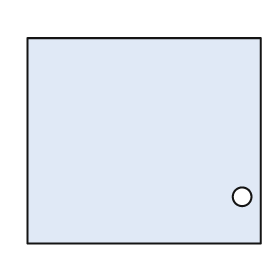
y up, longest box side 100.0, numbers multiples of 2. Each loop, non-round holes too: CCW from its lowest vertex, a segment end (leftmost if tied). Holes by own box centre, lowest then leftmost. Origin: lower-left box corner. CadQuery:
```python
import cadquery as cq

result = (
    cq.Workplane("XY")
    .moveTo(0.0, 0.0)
    .lineTo(100.0, 0.0)
    .lineTo(100.0, 88.0)
    .lineTo(0.0, 88.0)
    .close()
    .moveTo(92.0, 20.0)
    .circle(4.0)
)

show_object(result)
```